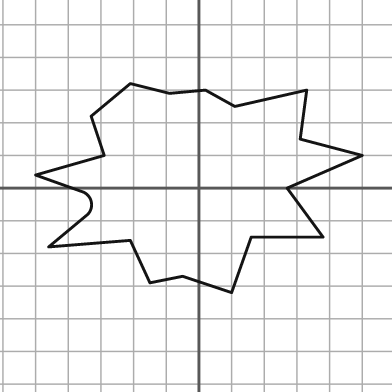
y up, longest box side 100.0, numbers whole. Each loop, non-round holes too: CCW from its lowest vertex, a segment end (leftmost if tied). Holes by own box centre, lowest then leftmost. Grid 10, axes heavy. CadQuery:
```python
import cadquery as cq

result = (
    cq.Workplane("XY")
    .moveTo(10.0, -32.0)
    .lineTo(16.0, -15.0)
    .lineTo(38.0, -15.0)
    .lineTo(27.0, 0.0)
    .lineTo(50.0, 10.0)
    .lineTo(31.0, 15.0)
    .lineTo(33.0, 30.0)
    .lineTo(11.0, 25.0)
    .lineTo(2.0, 30.0)
    .lineTo(-9.0, 29.0)
    .lineTo(-21.0, 32.0)
    .lineTo(-33.0, 22.0)
    .lineTo(-29.0, 10.0)
    .lineTo(-50.0, 4.0)
    .lineTo(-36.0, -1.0)
    .threePointArc((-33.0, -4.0), (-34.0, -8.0))
    .lineTo(-46.0, -18.0)
    .lineTo(-21.0, -16.0)
    .lineTo(-15.0, -29.0)
    .lineTo(-5.0, -27.0)
    .close()
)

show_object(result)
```